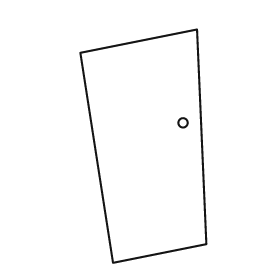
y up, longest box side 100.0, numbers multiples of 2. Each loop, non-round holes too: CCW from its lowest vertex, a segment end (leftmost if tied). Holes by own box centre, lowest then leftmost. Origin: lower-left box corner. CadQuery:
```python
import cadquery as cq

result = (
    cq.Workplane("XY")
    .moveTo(14.0, 0.0)
    .lineTo(54.0, 8.0)
    .lineTo(50.0, 100.0)
    .lineTo(0.0, 90.0)
    .close()
    .moveTo(44.0, 60.0)
    .circle(2.0)
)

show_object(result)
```